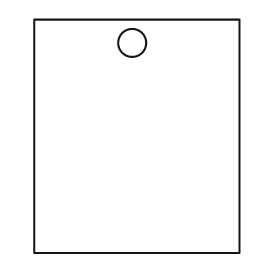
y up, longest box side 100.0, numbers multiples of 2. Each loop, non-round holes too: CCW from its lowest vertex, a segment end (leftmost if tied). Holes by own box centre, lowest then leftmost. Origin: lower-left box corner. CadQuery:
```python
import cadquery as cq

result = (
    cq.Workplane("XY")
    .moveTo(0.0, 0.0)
    .lineTo(88.0, 0.0)
    .lineTo(88.0, 100.0)
    .lineTo(0.0, 100.0)
    .close()
    .moveTo(42.0, 90.0)
    .circle(6.0)
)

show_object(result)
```